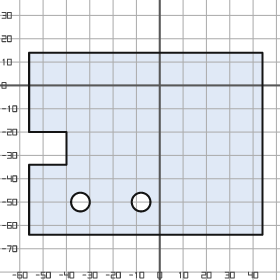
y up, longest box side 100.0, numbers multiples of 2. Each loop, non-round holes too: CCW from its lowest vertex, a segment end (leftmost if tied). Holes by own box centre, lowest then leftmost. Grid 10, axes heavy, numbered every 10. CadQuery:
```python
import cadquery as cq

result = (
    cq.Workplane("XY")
    .moveTo(-56.0, -64.0)
    .lineTo(44.0, -64.0)
    .lineTo(44.0, 14.0)
    .lineTo(-56.0, 14.0)
    .lineTo(-56.0, -20.0)
    .lineTo(-40.0, -20.0)
    .lineTo(-40.0, -34.0)
    .lineTo(-56.0, -34.0)
    .close()
    .moveTo(-34.0, -50.0)
    .circle(4.0)
    .moveTo(-8.0, -50.0)
    .circle(4.0)
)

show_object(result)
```